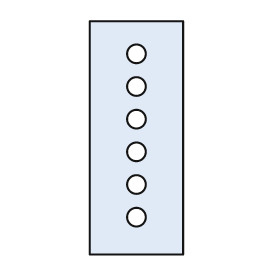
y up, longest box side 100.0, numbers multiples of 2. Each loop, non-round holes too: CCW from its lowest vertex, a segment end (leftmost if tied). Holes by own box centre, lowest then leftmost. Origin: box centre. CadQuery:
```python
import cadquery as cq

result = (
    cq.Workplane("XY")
    .moveTo(-20.0, -50.0)
    .lineTo(20.0, -50.0)
    .lineTo(20.0, 50.0)
    .lineTo(-20.0, 50.0)
    .close()
    .moveTo(0.0, -34.0)
    .circle(4.0)
    .moveTo(0.0, -20.0)
    .circle(4.0)
    .moveTo(0.0, -6.0)
    .circle(4.0)
    .moveTo(0.0, 8.0)
    .circle(4.0)
    .moveTo(0.0, 22.0)
    .circle(4.0)
    .moveTo(0.0, 36.0)
    .circle(4.0)
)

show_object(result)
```